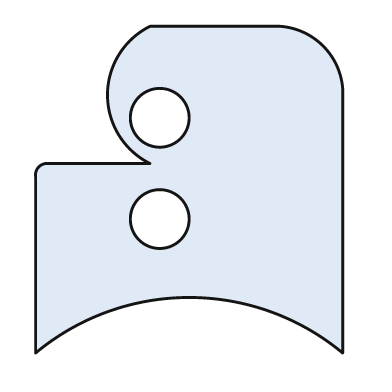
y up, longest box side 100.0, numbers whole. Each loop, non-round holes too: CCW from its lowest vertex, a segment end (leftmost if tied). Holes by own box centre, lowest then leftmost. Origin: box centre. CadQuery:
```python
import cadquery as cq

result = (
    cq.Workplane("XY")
    .moveTo(-47.0, -50.0)
    .threePointArc((0.0, -33.0), (47.0, -50.0))
    .lineTo(47.0, 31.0)
    .threePointArc((41.0, 44.0), (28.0, 50.0))
    .lineTo(-12.0, 50.0)
    .threePointArc((-25.0, 29.0), (-12.0, 8.0))
    .lineTo(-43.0, 8.0)
    .threePointArc((-46.0, 7.0), (-47.0, 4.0))
    .close()
    .moveTo(-9.0, -9.0)
    .circle(9.0)
    .moveTo(-9.0, 22.0)
    .circle(9.0)
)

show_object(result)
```